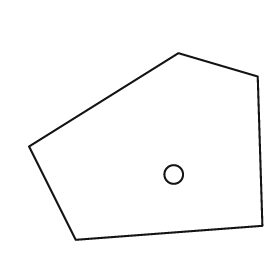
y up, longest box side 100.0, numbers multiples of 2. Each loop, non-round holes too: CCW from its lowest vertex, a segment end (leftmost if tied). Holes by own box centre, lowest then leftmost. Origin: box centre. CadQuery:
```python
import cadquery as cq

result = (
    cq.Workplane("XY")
    .moveTo(-30.0, -40.0)
    .lineTo(50.0, -34.0)
    .lineTo(48.0, 30.0)
    .lineTo(14.0, 40.0)
    .lineTo(-50.0, 0.0)
    .close()
    .moveTo(12.0, -12.0)
    .circle(4.0)
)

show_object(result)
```